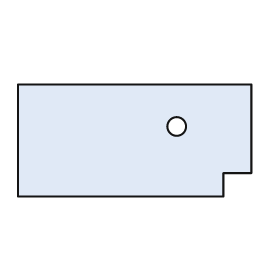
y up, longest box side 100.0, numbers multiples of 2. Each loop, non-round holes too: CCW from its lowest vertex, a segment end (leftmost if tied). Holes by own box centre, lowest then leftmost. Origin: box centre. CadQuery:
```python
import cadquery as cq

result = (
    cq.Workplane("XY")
    .moveTo(-50.0, -24.0)
    .lineTo(38.0, -24.0)
    .lineTo(38.0, -14.0)
    .lineTo(50.0, -14.0)
    .lineTo(50.0, 24.0)
    .lineTo(-50.0, 24.0)
    .close()
    .moveTo(18.0, 6.0)
    .circle(4.0)
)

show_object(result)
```